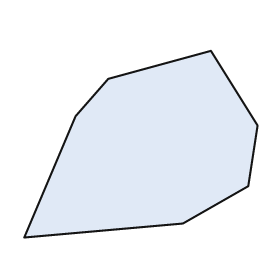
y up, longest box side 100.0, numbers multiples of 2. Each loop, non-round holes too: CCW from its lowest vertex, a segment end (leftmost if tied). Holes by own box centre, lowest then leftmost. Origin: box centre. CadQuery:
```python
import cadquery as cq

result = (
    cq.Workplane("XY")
    .moveTo(-50.0, -40.0)
    .lineTo(18.0, -34.0)
    .lineTo(46.0, -18.0)
    .lineTo(50.0, 8.0)
    .lineTo(30.0, 40.0)
    .lineTo(-14.0, 28.0)
    .lineTo(-28.0, 12.0)
    .close()
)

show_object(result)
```